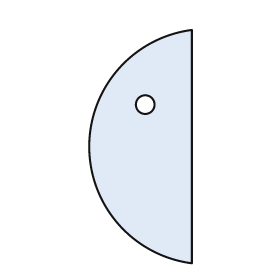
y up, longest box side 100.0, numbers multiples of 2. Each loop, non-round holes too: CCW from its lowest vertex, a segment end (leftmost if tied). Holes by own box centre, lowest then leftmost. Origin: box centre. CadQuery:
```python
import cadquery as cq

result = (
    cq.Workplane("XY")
    .moveTo(22.0, -50.0)
    .lineTo(22.0, 50.0)
    .threePointArc((-22.0, 0.0), (22.0, -50.0))
    .close()
    .moveTo(2.0, 18.0)
    .circle(4.0)
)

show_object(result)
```